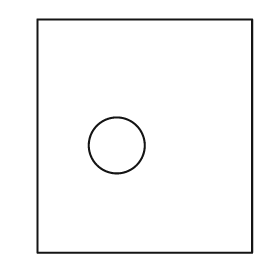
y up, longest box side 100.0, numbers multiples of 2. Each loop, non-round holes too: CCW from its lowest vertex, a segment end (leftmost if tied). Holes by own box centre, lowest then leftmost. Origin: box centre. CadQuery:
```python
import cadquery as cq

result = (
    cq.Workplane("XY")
    .moveTo(-46.0, -50.0)
    .lineTo(46.0, -50.0)
    .lineTo(46.0, 50.0)
    .lineTo(-46.0, 50.0)
    .close()
    .moveTo(-12.0, -4.0)
    .circle(12.0)
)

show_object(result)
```